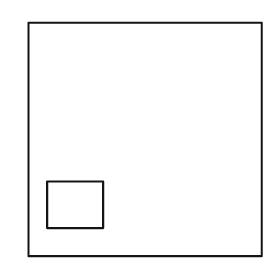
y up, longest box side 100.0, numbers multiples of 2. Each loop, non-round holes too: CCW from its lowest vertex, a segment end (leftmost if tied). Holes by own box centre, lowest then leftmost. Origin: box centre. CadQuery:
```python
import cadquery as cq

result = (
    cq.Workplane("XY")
    .moveTo(-50.0, -50.0)
    .lineTo(50.0, -50.0)
    .lineTo(50.0, 50.0)
    .lineTo(-50.0, 50.0)
    .close()
    .moveTo(-42.0, -38.0)
    .lineTo(-18.0, -38.0)
    .lineTo(-18.0, -18.0)
    .lineTo(-42.0, -18.0)
    .close()
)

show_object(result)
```